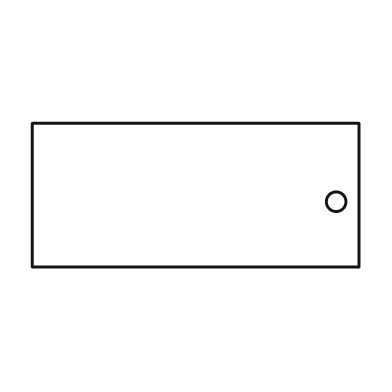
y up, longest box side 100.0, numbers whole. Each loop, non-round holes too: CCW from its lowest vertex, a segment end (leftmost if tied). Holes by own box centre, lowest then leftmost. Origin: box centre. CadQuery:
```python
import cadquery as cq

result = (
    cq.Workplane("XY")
    .moveTo(-50.0, -22.0)
    .lineTo(50.0, -22.0)
    .lineTo(50.0, 22.0)
    .lineTo(-50.0, 22.0)
    .close()
    .moveTo(43.0, -2.0)
    .circle(3.0)
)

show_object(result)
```